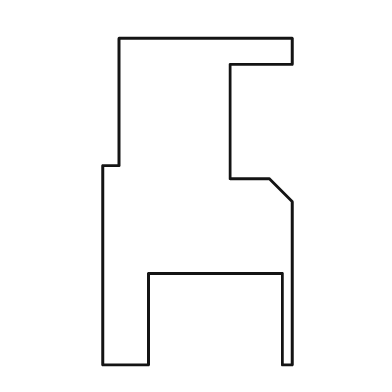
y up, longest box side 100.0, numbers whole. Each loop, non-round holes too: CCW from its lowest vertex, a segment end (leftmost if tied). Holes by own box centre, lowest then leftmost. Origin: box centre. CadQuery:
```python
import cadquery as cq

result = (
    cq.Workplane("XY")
    .moveTo(-29.0, -50.0)
    .lineTo(-15.0, -50.0)
    .lineTo(-15.0, -22.0)
    .lineTo(26.0, -22.0)
    .lineTo(26.0, -50.0)
    .lineTo(29.0, -50.0)
    .lineTo(29.0, 0.0)
    .lineTo(22.0, 7.0)
    .lineTo(10.0, 7.0)
    .lineTo(10.0, 42.0)
    .lineTo(29.0, 42.0)
    .lineTo(29.0, 50.0)
    .lineTo(-24.0, 50.0)
    .lineTo(-24.0, 11.0)
    .lineTo(-29.0, 11.0)
    .close()
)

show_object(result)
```